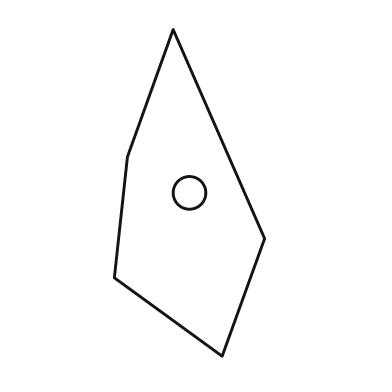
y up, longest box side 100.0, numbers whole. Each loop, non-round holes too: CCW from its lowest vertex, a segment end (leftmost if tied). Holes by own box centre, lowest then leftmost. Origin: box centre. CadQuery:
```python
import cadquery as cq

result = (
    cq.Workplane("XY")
    .moveTo(10.0, -50.0)
    .lineTo(23.0, -14.0)
    .lineTo(-5.0, 50.0)
    .lineTo(-19.0, 11.0)
    .lineTo(-23.0, -26.0)
    .close()
    .moveTo(0.0, 0.0)
    .circle(5.0)
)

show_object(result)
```